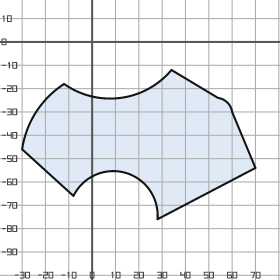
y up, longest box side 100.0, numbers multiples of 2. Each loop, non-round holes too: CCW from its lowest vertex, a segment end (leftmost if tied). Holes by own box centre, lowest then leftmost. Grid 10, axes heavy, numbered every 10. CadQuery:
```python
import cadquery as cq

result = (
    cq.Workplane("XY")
    .moveTo(28.0, -76.0)
    .lineTo(70.0, -54.0)
    .lineTo(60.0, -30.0)
    .threePointArc((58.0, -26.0), (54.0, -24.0))
    .lineTo(34.0, -12.0)
    .threePointArc((12.0, -24.0), (-12.0, -18.0))
    .threePointArc((-24.0, -30.0), (-30.0, -46.0))
    .lineTo(-8.0, -66.0)
    .threePointArc((14.0, -56.0), (28.0, -76.0))
    .close()
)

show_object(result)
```